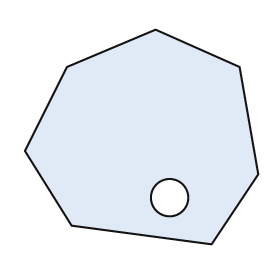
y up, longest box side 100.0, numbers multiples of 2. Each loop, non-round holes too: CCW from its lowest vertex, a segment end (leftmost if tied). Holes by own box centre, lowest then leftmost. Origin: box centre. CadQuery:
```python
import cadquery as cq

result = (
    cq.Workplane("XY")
    .moveTo(30.0, -46.0)
    .lineTo(50.0, -16.0)
    .lineTo(42.0, 30.0)
    .lineTo(6.0, 46.0)
    .lineTo(-32.0, 30.0)
    .lineTo(-50.0, -6.0)
    .lineTo(-30.0, -38.0)
    .close()
    .moveTo(12.0, -26.0)
    .circle(8.0)
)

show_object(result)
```